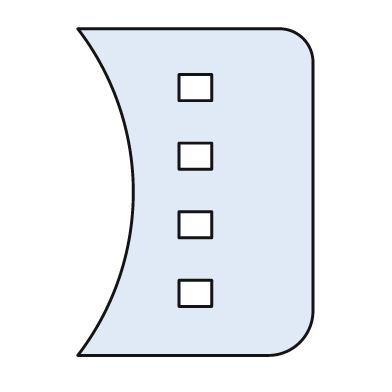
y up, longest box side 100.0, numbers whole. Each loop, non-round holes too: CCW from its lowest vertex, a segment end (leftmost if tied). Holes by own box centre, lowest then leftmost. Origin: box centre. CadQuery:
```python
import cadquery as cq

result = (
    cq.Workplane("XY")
    .moveTo(-36.0, -50.0)
    .lineTo(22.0, -50.0)
    .threePointArc((32.0, -46.0), (36.0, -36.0))
    .lineTo(36.0, 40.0)
    .threePointArc((33.0, 47.0), (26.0, 50.0))
    .lineTo(-36.0, 50.0)
    .threePointArc((-19.0, 0.0), (-36.0, -50.0))
    .close()
    .moveTo(-5.0, -35.0)
    .lineTo(5.0, -35.0)
    .lineTo(5.0, -27.0)
    .lineTo(-5.0, -27.0)
    .close()
    .moveTo(-5.0, -14.0)
    .lineTo(5.0, -14.0)
    .lineTo(5.0, -6.0)
    .lineTo(-5.0, -6.0)
    .close()
    .moveTo(-5.0, 7.0)
    .lineTo(5.0, 7.0)
    .lineTo(5.0, 15.0)
    .lineTo(-5.0, 15.0)
    .close()
    .moveTo(-5.0, 28.0)
    .lineTo(5.0, 28.0)
    .lineTo(5.0, 36.0)
    .lineTo(-5.0, 36.0)
    .close()
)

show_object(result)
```